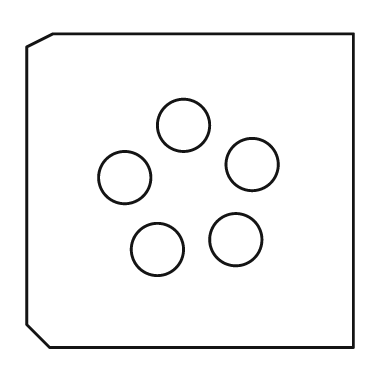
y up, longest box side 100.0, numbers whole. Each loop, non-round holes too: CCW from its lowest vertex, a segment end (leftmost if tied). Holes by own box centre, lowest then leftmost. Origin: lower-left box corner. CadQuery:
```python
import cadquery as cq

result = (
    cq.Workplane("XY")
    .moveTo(7.0, 0.0)
    .lineTo(100.0, 0.0)
    .lineTo(100.0, 96.0)
    .lineTo(8.0, 96.0)
    .lineTo(0.0, 92.0)
    .lineTo(0.0, 7.0)
    .close()
    .moveTo(40.0, 30.0)
    .circle(8.0)
    .moveTo(64.0, 33.0)
    .circle(8.0)
    .moveTo(30.0, 52.0)
    .circle(8.0)
    .moveTo(69.0, 56.0)
    .circle(8.0)
    .moveTo(48.0, 68.0)
    .circle(8.0)
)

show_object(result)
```